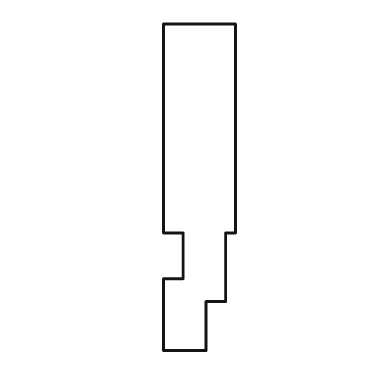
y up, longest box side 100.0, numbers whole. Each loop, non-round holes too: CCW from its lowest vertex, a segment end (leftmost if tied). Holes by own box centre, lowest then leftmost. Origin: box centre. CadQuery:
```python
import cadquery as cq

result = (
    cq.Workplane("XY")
    .moveTo(-11.0, -50.0)
    .lineTo(2.0, -50.0)
    .lineTo(2.0, -35.0)
    .lineTo(8.0, -35.0)
    .lineTo(8.0, -14.0)
    .lineTo(11.0, -14.0)
    .lineTo(11.0, 50.0)
    .lineTo(-11.0, 50.0)
    .lineTo(-11.0, -14.0)
    .lineTo(-5.0, -14.0)
    .lineTo(-5.0, -28.0)
    .lineTo(-11.0, -28.0)
    .close()
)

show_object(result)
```